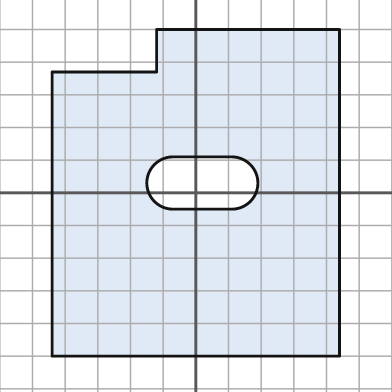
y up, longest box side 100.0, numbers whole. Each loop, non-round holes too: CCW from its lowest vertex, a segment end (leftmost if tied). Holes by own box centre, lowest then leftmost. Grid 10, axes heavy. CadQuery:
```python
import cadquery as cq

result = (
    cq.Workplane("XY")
    .moveTo(-44.0, -50.0)
    .lineTo(44.0, -50.0)
    .lineTo(44.0, 50.0)
    .lineTo(-12.0, 50.0)
    .lineTo(-12.0, 37.0)
    .lineTo(-44.0, 37.0)
    .close()
    .moveTo(-7.0, -5.0)
    .lineTo(11.0, -5.0)
    .threePointArc((19.0, 3.0), (11.0, 11.0))
    .lineTo(-7.0, 11.0)
    .threePointArc((-15.0, 3.0), (-7.0, -5.0))
    .close()
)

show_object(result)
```